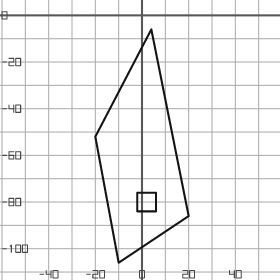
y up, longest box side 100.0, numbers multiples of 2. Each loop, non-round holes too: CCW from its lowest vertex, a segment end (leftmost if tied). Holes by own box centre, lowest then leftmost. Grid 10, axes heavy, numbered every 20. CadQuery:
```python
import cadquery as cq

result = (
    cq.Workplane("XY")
    .moveTo(-10.0, -106.0)
    .lineTo(20.0, -86.0)
    .lineTo(4.0, -6.0)
    .lineTo(-20.0, -52.0)
    .close()
    .moveTo(-2.0, -84.0)
    .lineTo(6.0, -84.0)
    .lineTo(6.0, -76.0)
    .lineTo(-2.0, -76.0)
    .close()
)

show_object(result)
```